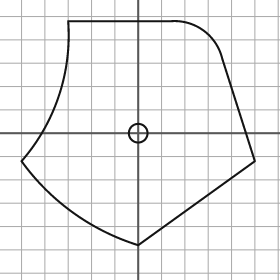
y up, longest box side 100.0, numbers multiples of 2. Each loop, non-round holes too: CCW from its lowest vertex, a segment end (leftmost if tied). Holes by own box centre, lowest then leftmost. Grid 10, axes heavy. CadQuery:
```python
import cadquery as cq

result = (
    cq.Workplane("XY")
    .moveTo(0.0, -48.0)
    .lineTo(50.0, -12.0)
    .lineTo(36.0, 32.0)
    .threePointArc((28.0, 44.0), (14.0, 48.0))
    .lineTo(-30.0, 48.0)
    .threePointArc((-34.0, 16.0), (-50.0, -12.0))
    .threePointArc((-28.0, -34.0), (0.0, -48.0))
    .close()
    .moveTo(0.0, 0.0)
    .circle(4.0)
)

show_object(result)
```